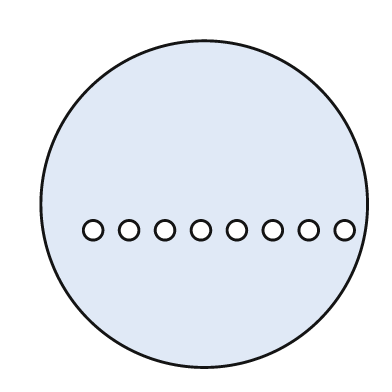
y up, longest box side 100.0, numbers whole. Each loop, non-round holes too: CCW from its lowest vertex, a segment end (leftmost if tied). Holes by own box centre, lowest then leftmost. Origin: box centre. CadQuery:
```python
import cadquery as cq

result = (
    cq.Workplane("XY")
    .moveTo(0.0, 0.0)
    .circle(50.0)
    .moveTo(-34.0, -8.0)
    .circle(3.0)
    .moveTo(-23.0, -8.0)
    .circle(3.0)
    .moveTo(-12.0, -8.0)
    .circle(3.0)
    .moveTo(-1.0, -8.0)
    .circle(3.0)
    .moveTo(10.0, -8.0)
    .circle(3.0)
    .moveTo(21.0, -8.0)
    .circle(3.0)
    .moveTo(32.0, -8.0)
    .circle(3.0)
    .moveTo(43.0, -8.0)
    .circle(3.0)
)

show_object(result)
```